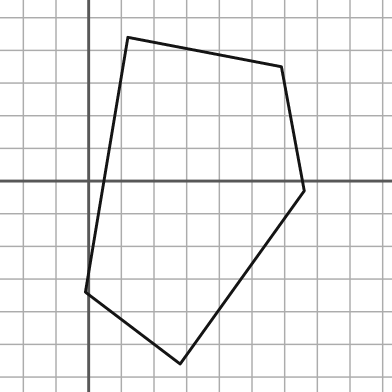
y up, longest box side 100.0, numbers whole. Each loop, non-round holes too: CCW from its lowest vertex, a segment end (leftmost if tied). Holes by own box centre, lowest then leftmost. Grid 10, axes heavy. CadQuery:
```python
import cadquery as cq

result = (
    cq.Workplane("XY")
    .moveTo(28.0, -56.0)
    .lineTo(66.0, -3.0)
    .lineTo(59.0, 35.0)
    .lineTo(12.0, 44.0)
    .lineTo(-1.0, -34.0)
    .close()
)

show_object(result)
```